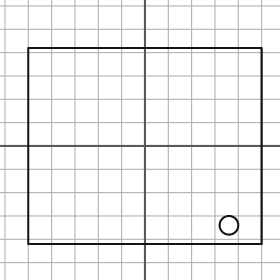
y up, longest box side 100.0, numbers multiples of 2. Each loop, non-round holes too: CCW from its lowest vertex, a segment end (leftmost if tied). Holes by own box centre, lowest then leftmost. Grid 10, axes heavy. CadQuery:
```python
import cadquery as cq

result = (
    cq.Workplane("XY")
    .moveTo(-50.0, -42.0)
    .lineTo(50.0, -42.0)
    .lineTo(50.0, 42.0)
    .lineTo(-50.0, 42.0)
    .close()
    .moveTo(36.0, -34.0)
    .circle(4.0)
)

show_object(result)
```